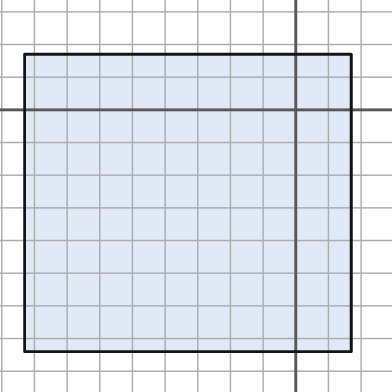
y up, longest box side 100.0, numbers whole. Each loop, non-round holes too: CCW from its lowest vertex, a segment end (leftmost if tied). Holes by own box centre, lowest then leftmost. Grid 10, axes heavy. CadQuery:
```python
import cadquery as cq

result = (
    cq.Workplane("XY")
    .moveTo(-83.0, -74.0)
    .lineTo(17.0, -74.0)
    .lineTo(17.0, 17.0)
    .lineTo(-83.0, 17.0)
    .close()
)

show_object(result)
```